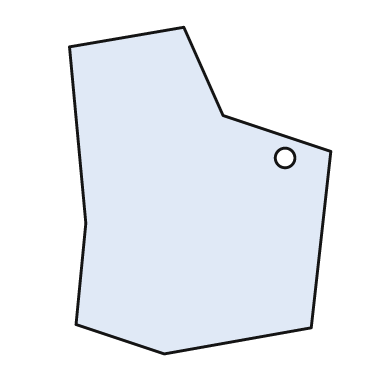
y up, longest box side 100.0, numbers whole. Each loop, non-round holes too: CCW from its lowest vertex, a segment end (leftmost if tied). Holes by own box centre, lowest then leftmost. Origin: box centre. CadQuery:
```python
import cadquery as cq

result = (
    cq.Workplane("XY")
    .moveTo(-11.0, -50.0)
    .lineTo(34.0, -42.0)
    .lineTo(40.0, 12.0)
    .lineTo(7.0, 23.0)
    .lineTo(-5.0, 50.0)
    .lineTo(-40.0, 44.0)
    .lineTo(-35.0, -10.0)
    .lineTo(-38.0, -41.0)
    .close()
    .moveTo(26.0, 10.0)
    .circle(3.0)
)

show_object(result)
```